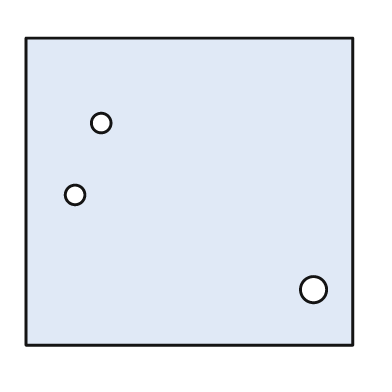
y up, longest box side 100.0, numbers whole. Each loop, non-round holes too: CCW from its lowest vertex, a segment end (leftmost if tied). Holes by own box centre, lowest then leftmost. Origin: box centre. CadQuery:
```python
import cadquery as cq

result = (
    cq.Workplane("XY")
    .moveTo(-50.0, -47.0)
    .lineTo(50.0, -47.0)
    .lineTo(50.0, 47.0)
    .lineTo(-50.0, 47.0)
    .close()
    .moveTo(38.0, -30.0)
    .circle(4.0)
    .moveTo(-35.0, -1.0)
    .circle(3.0)
    .moveTo(-27.0, 21.0)
    .circle(3.0)
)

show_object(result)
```